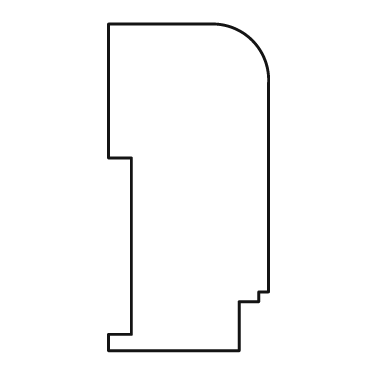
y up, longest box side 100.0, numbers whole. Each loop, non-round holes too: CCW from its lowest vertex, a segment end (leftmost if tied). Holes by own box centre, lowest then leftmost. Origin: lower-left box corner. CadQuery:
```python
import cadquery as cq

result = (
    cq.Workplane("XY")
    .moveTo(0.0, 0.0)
    .lineTo(40.0, 0.0)
    .lineTo(40.0, 15.0)
    .lineTo(46.0, 15.0)
    .lineTo(46.0, 18.0)
    .lineTo(49.0, 18.0)
    .lineTo(49.0, 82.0)
    .threePointArc((44.0, 95.0), (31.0, 100.0))
    .lineTo(0.0, 100.0)
    .lineTo(0.0, 59.0)
    .lineTo(7.0, 59.0)
    .lineTo(7.0, 5.0)
    .lineTo(0.0, 5.0)
    .close()
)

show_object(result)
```